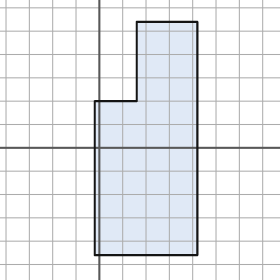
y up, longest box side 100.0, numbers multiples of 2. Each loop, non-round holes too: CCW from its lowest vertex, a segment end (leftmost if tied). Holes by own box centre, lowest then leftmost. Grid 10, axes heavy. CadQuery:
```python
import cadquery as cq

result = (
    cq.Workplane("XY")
    .moveTo(-2.0, -46.0)
    .lineTo(42.0, -46.0)
    .lineTo(42.0, 54.0)
    .lineTo(16.0, 54.0)
    .lineTo(16.0, 20.0)
    .lineTo(-2.0, 20.0)
    .close()
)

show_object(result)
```